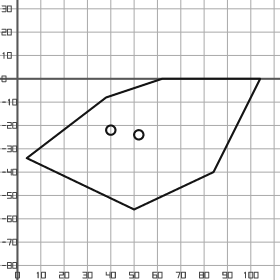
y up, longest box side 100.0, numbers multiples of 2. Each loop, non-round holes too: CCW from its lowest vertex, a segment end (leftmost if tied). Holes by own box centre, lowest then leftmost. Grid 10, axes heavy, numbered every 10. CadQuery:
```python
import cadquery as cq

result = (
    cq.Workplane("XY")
    .moveTo(50.0, -56.0)
    .lineTo(84.0, -40.0)
    .lineTo(104.0, 0.0)
    .lineTo(62.0, 0.0)
    .lineTo(38.0, -8.0)
    .lineTo(4.0, -34.0)
    .close()
    .moveTo(52.0, -24.0)
    .circle(2.0)
    .moveTo(40.0, -22.0)
    .circle(2.0)
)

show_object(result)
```